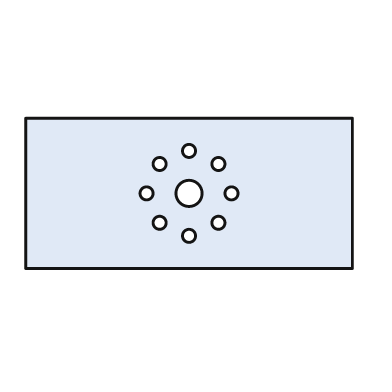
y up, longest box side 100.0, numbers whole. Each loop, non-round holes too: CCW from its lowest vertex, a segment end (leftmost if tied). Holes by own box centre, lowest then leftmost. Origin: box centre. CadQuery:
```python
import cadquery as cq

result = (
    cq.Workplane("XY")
    .moveTo(-50.0, -23.0)
    .lineTo(50.0, -23.0)
    .lineTo(50.0, 23.0)
    .lineTo(-50.0, 23.0)
    .close()
    .moveTo(0.0, -13.0)
    .circle(2.0)
    .moveTo(-9.0, -9.0)
    .circle(2.0)
    .moveTo(9.0, -9.0)
    .circle(2.0)
    .moveTo(-13.0, 0.0)
    .circle(2.0)
    .moveTo(0.0, 0.0)
    .circle(4.0)
    .moveTo(13.0, 0.0)
    .circle(2.0)
    .moveTo(-9.0, 9.0)
    .circle(2.0)
    .moveTo(9.0, 9.0)
    .circle(2.0)
    .moveTo(0.0, 13.0)
    .circle(2.0)
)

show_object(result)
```